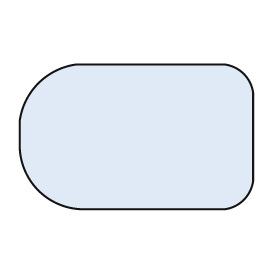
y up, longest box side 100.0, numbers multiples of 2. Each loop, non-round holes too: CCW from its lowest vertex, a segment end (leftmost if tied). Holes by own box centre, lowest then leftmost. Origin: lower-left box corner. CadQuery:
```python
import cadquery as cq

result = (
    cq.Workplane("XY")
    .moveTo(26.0, 0.0)
    .lineTo(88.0, 0.0)
    .threePointArc((96.0, 4.0), (100.0, 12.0))
    .lineTo(100.0, 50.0)
    .threePointArc((96.0, 58.0), (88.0, 62.0))
    .lineTo(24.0, 62.0)
    .threePointArc((8.0, 54.0), (0.0, 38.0))
    .lineTo(0.0, 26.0)
    .threePointArc((8.0, 8.0), (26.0, 0.0))
    .close()
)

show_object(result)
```